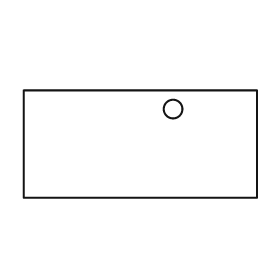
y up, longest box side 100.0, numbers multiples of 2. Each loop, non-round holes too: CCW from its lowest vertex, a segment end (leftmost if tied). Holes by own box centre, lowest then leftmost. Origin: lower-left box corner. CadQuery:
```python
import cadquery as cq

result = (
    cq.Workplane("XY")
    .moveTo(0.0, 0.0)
    .lineTo(100.0, 0.0)
    .lineTo(100.0, 46.0)
    .lineTo(0.0, 46.0)
    .close()
    .moveTo(64.0, 38.0)
    .circle(4.0)
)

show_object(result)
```